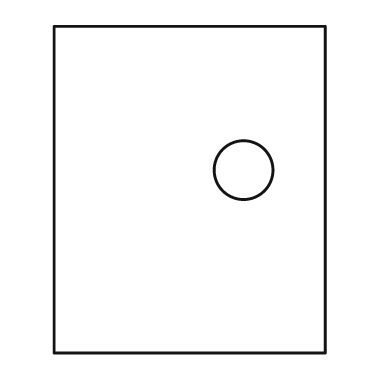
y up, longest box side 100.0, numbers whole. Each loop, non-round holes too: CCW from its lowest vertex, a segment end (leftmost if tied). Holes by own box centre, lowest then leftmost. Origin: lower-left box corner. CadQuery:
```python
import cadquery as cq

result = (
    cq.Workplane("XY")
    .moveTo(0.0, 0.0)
    .lineTo(83.0, 0.0)
    .lineTo(83.0, 100.0)
    .lineTo(0.0, 100.0)
    .close()
    .moveTo(58.0, 56.0)
    .circle(9.0)
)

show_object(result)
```